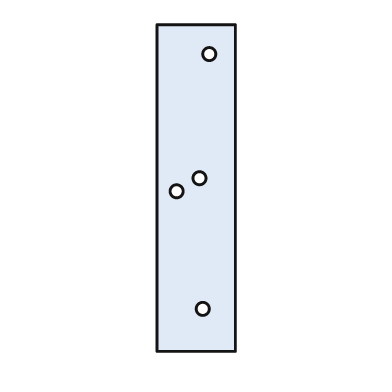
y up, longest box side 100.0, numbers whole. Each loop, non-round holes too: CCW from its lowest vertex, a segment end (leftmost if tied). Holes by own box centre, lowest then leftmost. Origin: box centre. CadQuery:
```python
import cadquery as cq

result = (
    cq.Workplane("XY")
    .moveTo(-12.0, -50.0)
    .lineTo(12.0, -50.0)
    .lineTo(12.0, 50.0)
    .lineTo(-12.0, 50.0)
    .close()
    .moveTo(2.0, -37.0)
    .circle(2.0)
    .moveTo(-6.0, -1.0)
    .circle(2.0)
    .moveTo(1.0, 3.0)
    .circle(2.0)
    .moveTo(4.0, 41.0)
    .circle(2.0)
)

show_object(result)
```